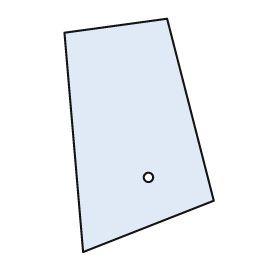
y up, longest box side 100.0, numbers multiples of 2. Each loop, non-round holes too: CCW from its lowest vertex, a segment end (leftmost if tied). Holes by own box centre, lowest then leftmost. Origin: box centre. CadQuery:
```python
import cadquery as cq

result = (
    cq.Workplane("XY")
    .moveTo(-24.0, -50.0)
    .lineTo(32.0, -28.0)
    .lineTo(12.0, 50.0)
    .lineTo(-32.0, 44.0)
    .close()
    .moveTo(4.0, -18.0)
    .circle(2.0)
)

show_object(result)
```